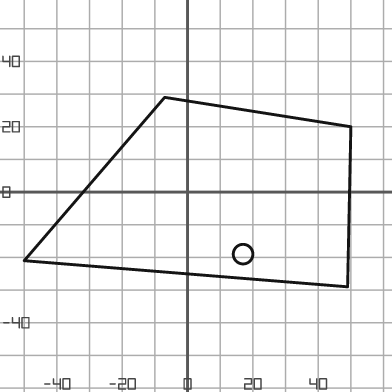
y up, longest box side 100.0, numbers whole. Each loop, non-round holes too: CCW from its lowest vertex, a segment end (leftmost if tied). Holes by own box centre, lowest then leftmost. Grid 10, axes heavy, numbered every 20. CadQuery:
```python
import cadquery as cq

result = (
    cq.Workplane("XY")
    .moveTo(49.0, -29.0)
    .lineTo(50.0, 20.0)
    .lineTo(-7.0, 29.0)
    .lineTo(-50.0, -21.0)
    .close()
    .moveTo(17.0, -19.0)
    .circle(3.0)
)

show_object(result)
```